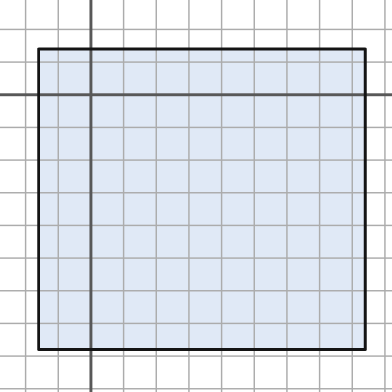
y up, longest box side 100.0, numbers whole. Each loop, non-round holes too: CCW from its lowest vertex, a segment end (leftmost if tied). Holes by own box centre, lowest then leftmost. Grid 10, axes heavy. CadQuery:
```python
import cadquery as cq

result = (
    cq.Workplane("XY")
    .moveTo(-16.0, -78.0)
    .lineTo(84.0, -78.0)
    .lineTo(84.0, 14.0)
    .lineTo(-16.0, 14.0)
    .close()
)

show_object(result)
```